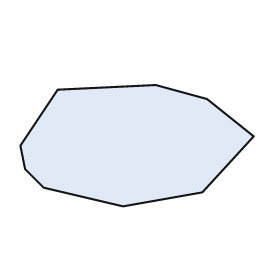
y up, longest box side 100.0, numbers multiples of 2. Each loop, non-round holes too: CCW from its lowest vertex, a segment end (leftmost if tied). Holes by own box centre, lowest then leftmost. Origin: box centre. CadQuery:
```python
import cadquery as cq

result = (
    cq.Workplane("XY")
    .moveTo(-6.0, -26.0)
    .lineTo(28.0, -20.0)
    .lineTo(50.0, 4.0)
    .lineTo(30.0, 20.0)
    .lineTo(8.0, 26.0)
    .lineTo(-34.0, 24.0)
    .lineTo(-50.0, 0.0)
    .lineTo(-48.0, -10.0)
    .lineTo(-40.0, -18.0)
    .close()
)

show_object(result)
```